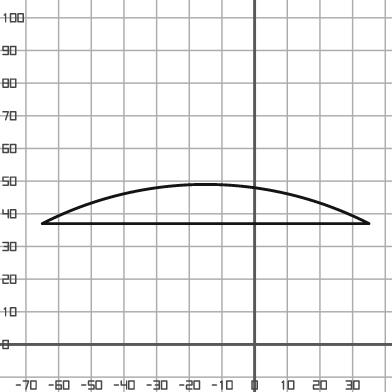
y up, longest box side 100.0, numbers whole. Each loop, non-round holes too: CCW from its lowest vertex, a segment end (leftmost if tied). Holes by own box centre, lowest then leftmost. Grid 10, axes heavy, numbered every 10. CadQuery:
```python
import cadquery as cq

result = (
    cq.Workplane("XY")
    .moveTo(-65.0, 37.0)
    .lineTo(35.0, 37.0)
    .threePointArc((-15.0, 49.0), (-65.0, 37.0))
    .close()
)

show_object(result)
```